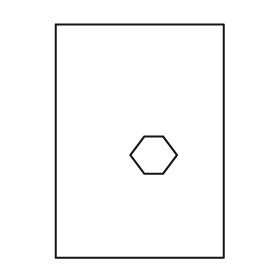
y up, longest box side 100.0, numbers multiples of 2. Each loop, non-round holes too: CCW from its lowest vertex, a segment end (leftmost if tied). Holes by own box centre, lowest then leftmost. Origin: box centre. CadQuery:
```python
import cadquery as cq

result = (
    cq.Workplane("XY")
    .moveTo(-36.0, -50.0)
    .lineTo(36.0, -50.0)
    .lineTo(36.0, 50.0)
    .lineTo(-36.0, 50.0)
    .close()
    .moveTo(2.0, -14.0)
    .lineTo(10.0, -14.0)
    .lineTo(16.0, -6.0)
    .lineTo(10.0, 2.0)
    .lineTo(2.0, 2.0)
    .lineTo(-4.0, -6.0)
    .close()
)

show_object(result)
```